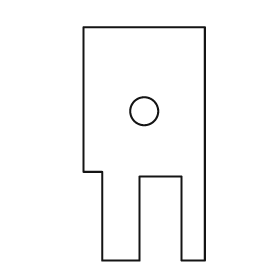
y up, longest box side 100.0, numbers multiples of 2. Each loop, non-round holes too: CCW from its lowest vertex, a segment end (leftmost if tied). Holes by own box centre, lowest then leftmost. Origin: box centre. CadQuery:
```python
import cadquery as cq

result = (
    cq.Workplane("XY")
    .moveTo(-18.0, -50.0)
    .lineTo(-2.0, -50.0)
    .lineTo(-2.0, -14.0)
    .lineTo(16.0, -14.0)
    .lineTo(16.0, -50.0)
    .lineTo(26.0, -50.0)
    .lineTo(26.0, 50.0)
    .lineTo(-26.0, 50.0)
    .lineTo(-26.0, -12.0)
    .lineTo(-18.0, -12.0)
    .close()
    .moveTo(0.0, 14.0)
    .circle(6.0)
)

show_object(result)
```